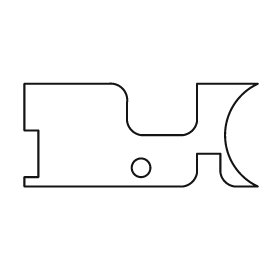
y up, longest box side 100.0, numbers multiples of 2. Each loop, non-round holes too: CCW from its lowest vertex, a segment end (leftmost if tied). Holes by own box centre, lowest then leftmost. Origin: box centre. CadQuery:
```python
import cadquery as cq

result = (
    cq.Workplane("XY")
    .moveTo(-50.0, -22.0)
    .lineTo(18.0, -22.0)
    .threePointArc((22.0, -20.0), (24.0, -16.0))
    .lineTo(24.0, -8.0)
    .lineTo(34.0, -8.0)
    .lineTo(34.0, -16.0)
    .threePointArc((36.0, -20.0), (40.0, -22.0))
    .lineTo(50.0, -22.0)
    .threePointArc((36.0, 0.0), (50.0, 22.0))
    .lineTo(24.0, 22.0)
    .lineTo(24.0, 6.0)
    .threePointArc((22.0, 2.0), (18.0, 0.0))
    .lineTo(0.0, 0.0)
    .threePointArc((-4.0, 2.0), (-6.0, 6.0))
    .lineTo(-6.0, 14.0)
    .threePointArc((-8.0, 20.0), (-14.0, 22.0))
    .lineTo(-50.0, 22.0)
    .lineTo(-50.0, 2.0)
    .lineTo(-44.0, 2.0)
    .lineTo(-44.0, -18.0)
    .lineTo(-50.0, -18.0)
    .close()
    .moveTo(0.0, -14.0)
    .circle(4.0)
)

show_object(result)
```